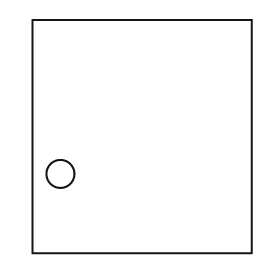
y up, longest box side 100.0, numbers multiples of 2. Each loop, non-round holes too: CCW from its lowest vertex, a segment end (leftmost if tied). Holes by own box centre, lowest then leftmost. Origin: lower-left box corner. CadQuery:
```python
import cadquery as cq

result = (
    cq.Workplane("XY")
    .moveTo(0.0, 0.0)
    .lineTo(94.0, 0.0)
    .lineTo(94.0, 100.0)
    .lineTo(0.0, 100.0)
    .close()
    .moveTo(12.0, 34.0)
    .circle(6.0)
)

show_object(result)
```